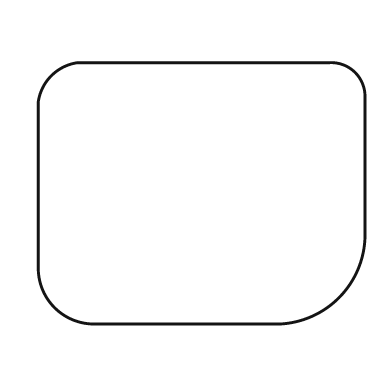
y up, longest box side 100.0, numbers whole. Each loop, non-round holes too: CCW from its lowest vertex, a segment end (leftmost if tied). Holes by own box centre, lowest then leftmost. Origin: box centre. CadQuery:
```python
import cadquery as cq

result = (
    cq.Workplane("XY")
    .moveTo(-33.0, -40.0)
    .lineTo(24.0, -40.0)
    .threePointArc((42.0, -32.0), (50.0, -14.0))
    .lineTo(50.0, 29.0)
    .threePointArc((47.0, 37.0), (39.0, 40.0))
    .lineTo(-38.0, 40.0)
    .threePointArc((-46.0, 36.0), (-50.0, 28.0))
    .lineTo(-50.0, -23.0)
    .threePointArc((-45.0, -35.0), (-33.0, -40.0))
    .close()
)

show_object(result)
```